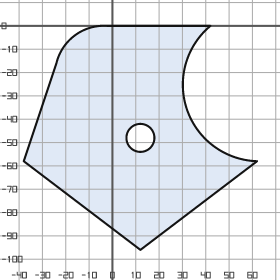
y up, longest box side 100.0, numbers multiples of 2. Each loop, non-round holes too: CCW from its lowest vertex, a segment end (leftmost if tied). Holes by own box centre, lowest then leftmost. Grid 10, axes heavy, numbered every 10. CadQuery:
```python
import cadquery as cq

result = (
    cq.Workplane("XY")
    .moveTo(12.0, -96.0)
    .lineTo(62.0, -58.0)
    .threePointArc((32.0, -36.0), (42.0, 0.0))
    .lineTo(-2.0, 0.0)
    .threePointArc((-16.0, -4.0), (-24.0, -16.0))
    .lineTo(-38.0, -58.0)
    .close()
    .moveTo(12.0, -48.0)
    .circle(6.0)
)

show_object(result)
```